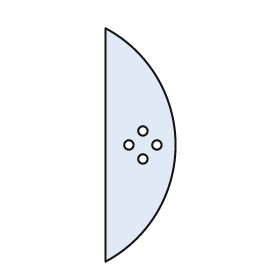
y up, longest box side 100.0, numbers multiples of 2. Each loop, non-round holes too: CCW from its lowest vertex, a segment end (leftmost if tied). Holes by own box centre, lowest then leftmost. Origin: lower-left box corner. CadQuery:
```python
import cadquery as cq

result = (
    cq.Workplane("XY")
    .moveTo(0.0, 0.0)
    .threePointArc((30.0, 50.0), (0.0, 100.0))
    .close()
    .moveTo(16.0, 44.0)
    .circle(2.0)
    .moveTo(10.0, 50.0)
    .circle(2.0)
    .moveTo(22.0, 50.0)
    .circle(2.0)
    .moveTo(16.0, 56.0)
    .circle(2.0)
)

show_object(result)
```